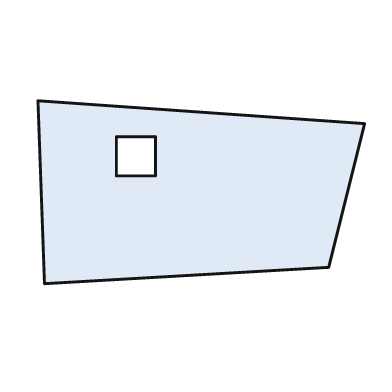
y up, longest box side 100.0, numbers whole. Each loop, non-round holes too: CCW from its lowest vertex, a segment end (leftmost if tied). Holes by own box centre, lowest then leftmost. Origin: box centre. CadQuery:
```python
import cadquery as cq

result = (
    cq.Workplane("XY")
    .moveTo(-48.0, -28.0)
    .lineTo(39.0, -23.0)
    .lineTo(50.0, 21.0)
    .lineTo(-50.0, 28.0)
    .close()
    .moveTo(-26.0, 5.0)
    .lineTo(-14.0, 5.0)
    .lineTo(-14.0, 17.0)
    .lineTo(-26.0, 17.0)
    .close()
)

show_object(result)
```